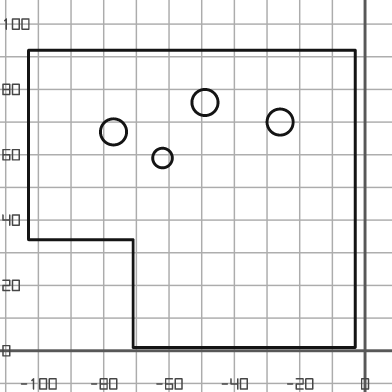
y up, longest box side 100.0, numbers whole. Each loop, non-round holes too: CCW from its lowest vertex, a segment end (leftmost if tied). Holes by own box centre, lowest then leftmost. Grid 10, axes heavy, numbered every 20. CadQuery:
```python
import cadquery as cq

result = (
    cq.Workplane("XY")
    .moveTo(-71.0, 1.0)
    .lineTo(-3.0, 1.0)
    .lineTo(-3.0, 92.0)
    .lineTo(-103.0, 92.0)
    .lineTo(-103.0, 34.0)
    .lineTo(-71.0, 34.0)
    .close()
    .moveTo(-62.0, 59.0)
    .circle(3.0)
    .moveTo(-77.0, 67.0)
    .circle(4.0)
    .moveTo(-26.0, 70.0)
    .circle(4.0)
    .moveTo(-49.0, 76.0)
    .circle(4.0)
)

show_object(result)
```